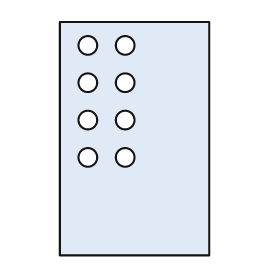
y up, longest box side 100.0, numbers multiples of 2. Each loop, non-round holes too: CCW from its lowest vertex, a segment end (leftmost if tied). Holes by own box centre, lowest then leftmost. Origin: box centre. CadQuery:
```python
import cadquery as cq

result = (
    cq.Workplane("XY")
    .moveTo(-32.0, -50.0)
    .lineTo(32.0, -50.0)
    .lineTo(32.0, 50.0)
    .lineTo(-32.0, 50.0)
    .close()
    .moveTo(-20.0, -8.0)
    .circle(4.0)
    .moveTo(-4.0, -8.0)
    .circle(4.0)
    .moveTo(-20.0, 8.0)
    .circle(4.0)
    .moveTo(-4.0, 8.0)
    .circle(4.0)
    .moveTo(-20.0, 24.0)
    .circle(4.0)
    .moveTo(-4.0, 24.0)
    .circle(4.0)
    .moveTo(-20.0, 40.0)
    .circle(4.0)
    .moveTo(-4.0, 40.0)
    .circle(4.0)
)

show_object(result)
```